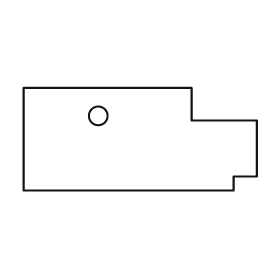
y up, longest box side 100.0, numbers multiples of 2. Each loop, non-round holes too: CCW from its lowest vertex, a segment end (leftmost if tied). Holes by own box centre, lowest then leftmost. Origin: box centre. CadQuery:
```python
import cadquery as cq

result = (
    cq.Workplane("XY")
    .moveTo(-50.0, -22.0)
    .lineTo(40.0, -22.0)
    .lineTo(40.0, -16.0)
    .lineTo(50.0, -16.0)
    .lineTo(50.0, 8.0)
    .lineTo(22.0, 8.0)
    .lineTo(22.0, 22.0)
    .lineTo(-50.0, 22.0)
    .close()
    .moveTo(-18.0, 10.0)
    .circle(4.0)
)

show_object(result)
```